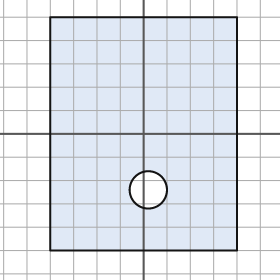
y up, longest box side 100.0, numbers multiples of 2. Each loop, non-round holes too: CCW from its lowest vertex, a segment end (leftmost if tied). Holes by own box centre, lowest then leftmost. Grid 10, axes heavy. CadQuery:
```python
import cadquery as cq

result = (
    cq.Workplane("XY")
    .moveTo(-40.0, -50.0)
    .lineTo(40.0, -50.0)
    .lineTo(40.0, 50.0)
    .lineTo(-40.0, 50.0)
    .close()
    .moveTo(2.0, -24.0)
    .circle(8.0)
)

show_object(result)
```